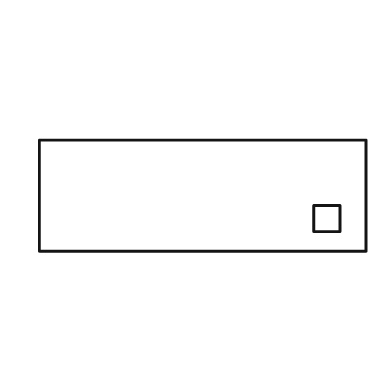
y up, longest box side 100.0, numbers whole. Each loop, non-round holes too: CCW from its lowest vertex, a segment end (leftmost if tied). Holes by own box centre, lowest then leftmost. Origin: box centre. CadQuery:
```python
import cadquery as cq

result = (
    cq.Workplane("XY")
    .moveTo(-50.0, -17.0)
    .lineTo(50.0, -17.0)
    .lineTo(50.0, 17.0)
    .lineTo(-50.0, 17.0)
    .close()
    .moveTo(34.0, -11.0)
    .lineTo(42.0, -11.0)
    .lineTo(42.0, -3.0)
    .lineTo(34.0, -3.0)
    .close()
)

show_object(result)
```